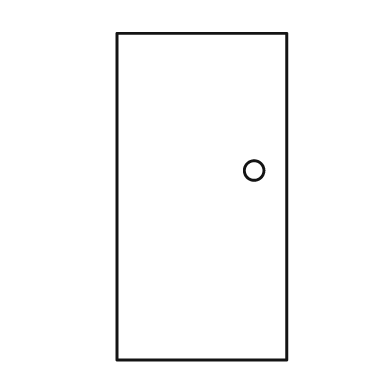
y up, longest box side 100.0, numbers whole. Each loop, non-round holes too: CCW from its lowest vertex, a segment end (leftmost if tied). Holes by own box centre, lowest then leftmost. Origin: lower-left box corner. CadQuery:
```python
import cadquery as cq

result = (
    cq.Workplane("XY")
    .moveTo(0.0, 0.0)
    .lineTo(52.0, 0.0)
    .lineTo(52.0, 100.0)
    .lineTo(0.0, 100.0)
    .close()
    .moveTo(42.0, 58.0)
    .circle(3.0)
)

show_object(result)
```